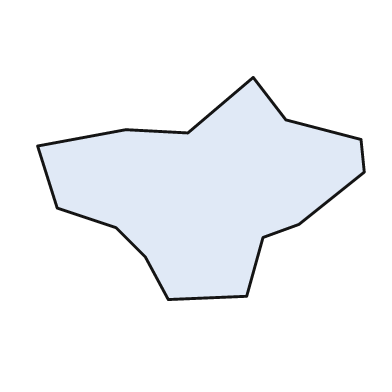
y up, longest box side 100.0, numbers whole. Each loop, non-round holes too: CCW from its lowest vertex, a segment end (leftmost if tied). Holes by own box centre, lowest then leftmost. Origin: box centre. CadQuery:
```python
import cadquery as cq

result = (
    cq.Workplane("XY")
    .moveTo(-10.0, -34.0)
    .lineTo(14.0, -33.0)
    .lineTo(19.0, -15.0)
    .lineTo(30.0, -11.0)
    .lineTo(50.0, 5.0)
    .lineTo(49.0, 15.0)
    .lineTo(26.0, 21.0)
    .lineTo(16.0, 34.0)
    .lineTo(-4.0, 17.0)
    .lineTo(-23.0, 18.0)
    .lineTo(-50.0, 13.0)
    .lineTo(-44.0, -6.0)
    .lineTo(-26.0, -12.0)
    .lineTo(-17.0, -21.0)
    .close()
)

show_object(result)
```